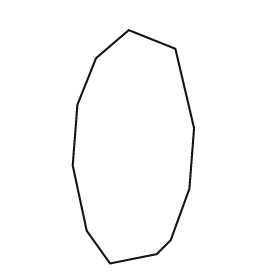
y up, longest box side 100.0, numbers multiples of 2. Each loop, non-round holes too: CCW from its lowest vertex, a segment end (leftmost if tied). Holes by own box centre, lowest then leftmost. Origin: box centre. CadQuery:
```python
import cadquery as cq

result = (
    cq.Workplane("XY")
    .moveTo(-10.0, -50.0)
    .lineTo(10.0, -46.0)
    .lineTo(16.0, -40.0)
    .lineTo(24.0, -18.0)
    .lineTo(26.0, 8.0)
    .lineTo(18.0, 42.0)
    .lineTo(-2.0, 50.0)
    .lineTo(-16.0, 38.0)
    .lineTo(-24.0, 18.0)
    .lineTo(-26.0, -8.0)
    .lineTo(-20.0, -36.0)
    .close()
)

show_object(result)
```